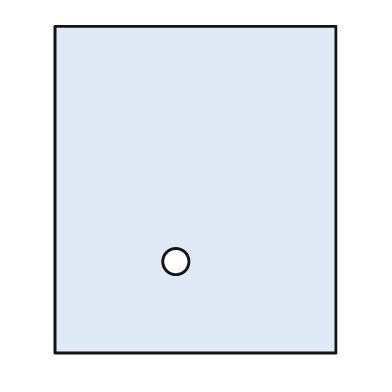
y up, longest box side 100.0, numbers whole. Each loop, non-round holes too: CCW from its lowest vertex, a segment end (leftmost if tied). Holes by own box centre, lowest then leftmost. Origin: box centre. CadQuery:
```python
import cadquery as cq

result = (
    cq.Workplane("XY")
    .moveTo(-43.0, -50.0)
    .lineTo(43.0, -50.0)
    .lineTo(43.0, 50.0)
    .lineTo(-43.0, 50.0)
    .close()
    .moveTo(-6.0, -22.0)
    .circle(4.0)
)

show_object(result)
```